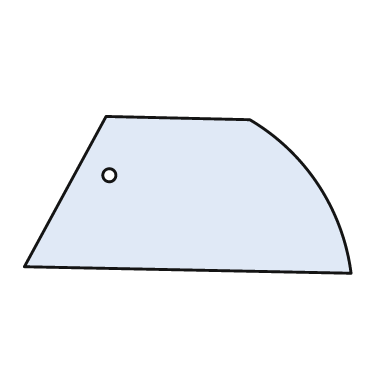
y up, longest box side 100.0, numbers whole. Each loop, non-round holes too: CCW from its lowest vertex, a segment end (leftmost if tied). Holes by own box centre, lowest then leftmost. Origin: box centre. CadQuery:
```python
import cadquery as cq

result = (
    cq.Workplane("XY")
    .moveTo(50.0, -24.0)
    .threePointArc((40.0, 3.0), (19.0, 23.0))
    .lineTo(-25.0, 24.0)
    .lineTo(-50.0, -22.0)
    .close()
    .moveTo(-24.0, 6.0)
    .circle(2.0)
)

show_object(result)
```